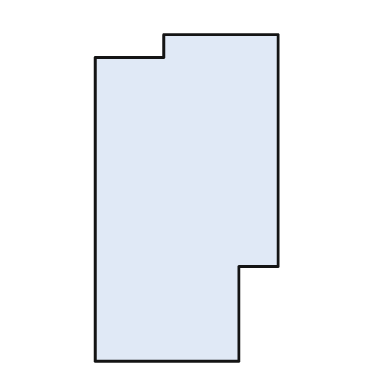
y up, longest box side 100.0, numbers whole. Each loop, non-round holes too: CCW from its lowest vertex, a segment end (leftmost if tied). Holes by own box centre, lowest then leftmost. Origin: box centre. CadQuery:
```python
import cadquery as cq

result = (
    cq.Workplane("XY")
    .moveTo(-28.0, -50.0)
    .lineTo(16.0, -50.0)
    .lineTo(16.0, -21.0)
    .lineTo(28.0, -21.0)
    .lineTo(28.0, 50.0)
    .lineTo(-7.0, 50.0)
    .lineTo(-7.0, 43.0)
    .lineTo(-28.0, 43.0)
    .close()
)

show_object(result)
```